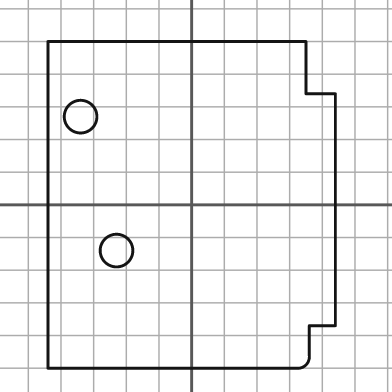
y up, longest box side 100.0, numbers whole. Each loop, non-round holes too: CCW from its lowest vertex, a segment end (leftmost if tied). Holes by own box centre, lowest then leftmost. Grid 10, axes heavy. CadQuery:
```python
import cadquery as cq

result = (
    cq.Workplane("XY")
    .moveTo(-44.0, -50.0)
    .lineTo(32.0, -50.0)
    .threePointArc((35.0, -49.0), (36.0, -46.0))
    .lineTo(36.0, -37.0)
    .lineTo(44.0, -37.0)
    .lineTo(44.0, 34.0)
    .lineTo(35.0, 34.0)
    .lineTo(35.0, 50.0)
    .lineTo(-44.0, 50.0)
    .close()
    .moveTo(-23.0, -14.0)
    .circle(5.0)
    .moveTo(-34.0, 27.0)
    .circle(5.0)
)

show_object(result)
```